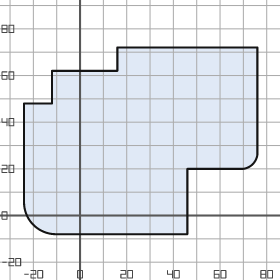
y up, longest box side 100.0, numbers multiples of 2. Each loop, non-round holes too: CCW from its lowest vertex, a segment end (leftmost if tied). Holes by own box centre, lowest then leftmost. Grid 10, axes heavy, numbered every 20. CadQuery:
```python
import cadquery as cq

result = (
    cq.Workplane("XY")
    .moveTo(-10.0, -8.0)
    .lineTo(46.0, -8.0)
    .lineTo(46.0, 20.0)
    .lineTo(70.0, 20.0)
    .threePointArc((74.0, 22.0), (76.0, 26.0))
    .lineTo(76.0, 72.0)
    .lineTo(16.0, 72.0)
    .lineTo(16.0, 62.0)
    .lineTo(-12.0, 62.0)
    .lineTo(-12.0, 48.0)
    .lineTo(-24.0, 48.0)
    .lineTo(-24.0, 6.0)
    .threePointArc((-20.0, -4.0), (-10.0, -8.0))
    .close()
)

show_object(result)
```